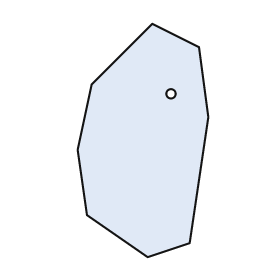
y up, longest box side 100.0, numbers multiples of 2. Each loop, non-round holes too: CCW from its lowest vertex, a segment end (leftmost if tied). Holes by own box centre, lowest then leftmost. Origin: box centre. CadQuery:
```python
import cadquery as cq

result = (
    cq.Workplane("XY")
    .moveTo(2.0, -50.0)
    .lineTo(20.0, -44.0)
    .lineTo(28.0, 10.0)
    .lineTo(24.0, 40.0)
    .lineTo(4.0, 50.0)
    .lineTo(-22.0, 24.0)
    .lineTo(-28.0, -4.0)
    .lineTo(-24.0, -32.0)
    .close()
    .moveTo(12.0, 20.0)
    .circle(2.0)
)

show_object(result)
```